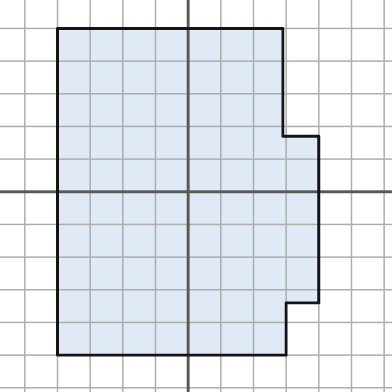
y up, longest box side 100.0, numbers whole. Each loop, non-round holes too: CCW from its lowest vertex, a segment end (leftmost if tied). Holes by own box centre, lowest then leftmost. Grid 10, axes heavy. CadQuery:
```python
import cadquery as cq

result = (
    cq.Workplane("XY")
    .moveTo(-40.0, -50.0)
    .lineTo(30.0, -50.0)
    .lineTo(30.0, -34.0)
    .lineTo(40.0, -34.0)
    .lineTo(40.0, 17.0)
    .lineTo(29.0, 17.0)
    .lineTo(29.0, 50.0)
    .lineTo(-40.0, 50.0)
    .close()
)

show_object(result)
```